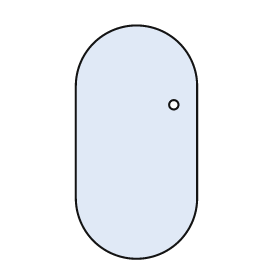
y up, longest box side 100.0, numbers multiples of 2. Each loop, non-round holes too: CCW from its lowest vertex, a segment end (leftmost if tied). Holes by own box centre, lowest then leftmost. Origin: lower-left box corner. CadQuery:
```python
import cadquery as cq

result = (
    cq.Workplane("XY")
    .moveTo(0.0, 26.0)
    .threePointArc((26.0, 0.0), (52.0, 26.0))
    .lineTo(52.0, 74.0)
    .threePointArc((26.0, 100.0), (0.0, 74.0))
    .close()
    .moveTo(42.0, 66.0)
    .circle(2.0)
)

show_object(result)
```